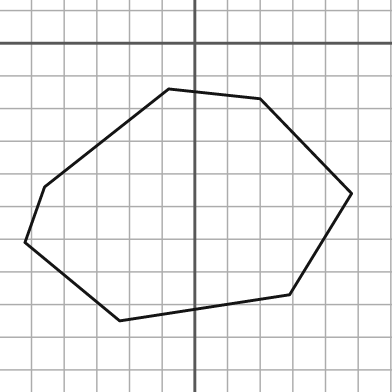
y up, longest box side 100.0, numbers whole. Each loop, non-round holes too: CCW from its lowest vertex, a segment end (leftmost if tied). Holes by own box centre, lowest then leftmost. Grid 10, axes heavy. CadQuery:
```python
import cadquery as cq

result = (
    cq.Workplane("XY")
    .moveTo(-23.0, -85.0)
    .lineTo(29.0, -77.0)
    .lineTo(48.0, -46.0)
    .lineTo(20.0, -17.0)
    .lineTo(-8.0, -14.0)
    .lineTo(-46.0, -44.0)
    .lineTo(-52.0, -61.0)
    .close()
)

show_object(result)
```